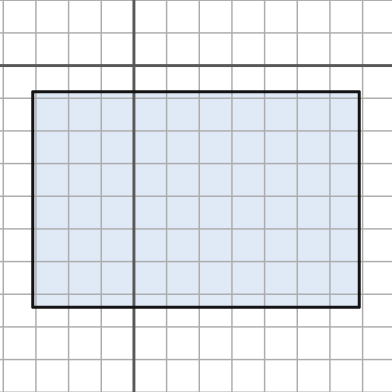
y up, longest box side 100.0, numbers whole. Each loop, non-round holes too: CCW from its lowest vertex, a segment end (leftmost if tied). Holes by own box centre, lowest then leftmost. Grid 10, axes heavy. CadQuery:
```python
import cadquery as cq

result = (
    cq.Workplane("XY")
    .moveTo(-31.0, -74.0)
    .lineTo(69.0, -74.0)
    .lineTo(69.0, -8.0)
    .lineTo(-31.0, -8.0)
    .close()
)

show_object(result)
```